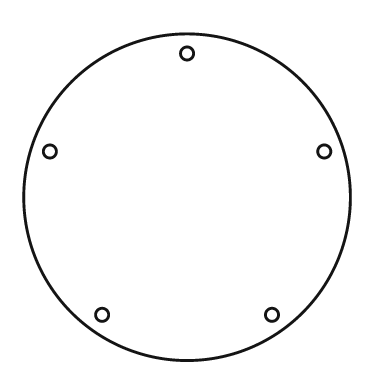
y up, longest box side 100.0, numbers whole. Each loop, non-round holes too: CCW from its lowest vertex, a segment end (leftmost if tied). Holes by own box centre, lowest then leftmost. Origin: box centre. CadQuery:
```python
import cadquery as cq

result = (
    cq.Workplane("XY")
    .moveTo(0.0, 0.0)
    .circle(50.0)
    .moveTo(-26.0, -36.0)
    .circle(2.0)
    .moveTo(26.0, -36.0)
    .circle(2.0)
    .moveTo(-42.0, 14.0)
    .circle(2.0)
    .moveTo(42.0, 14.0)
    .circle(2.0)
    .moveTo(0.0, 44.0)
    .circle(2.0)
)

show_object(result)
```